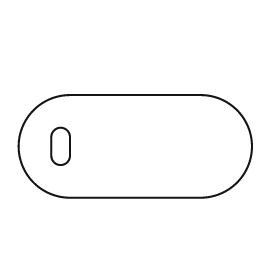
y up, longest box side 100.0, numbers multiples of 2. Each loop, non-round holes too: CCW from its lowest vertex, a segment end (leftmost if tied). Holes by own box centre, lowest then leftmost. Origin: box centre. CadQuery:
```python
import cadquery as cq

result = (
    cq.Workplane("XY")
    .moveTo(-28.0, -22.0)
    .lineTo(28.0, -22.0)
    .threePointArc((50.0, 0.0), (28.0, 22.0))
    .lineTo(-28.0, 22.0)
    .threePointArc((-50.0, 0.0), (-28.0, -22.0))
    .close()
    .moveTo(-36.0, -4.0)
    .threePointArc((-32.0, -8.0), (-28.0, -4.0))
    .lineTo(-28.0, 4.0)
    .threePointArc((-32.0, 8.0), (-36.0, 4.0))
    .close()
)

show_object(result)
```